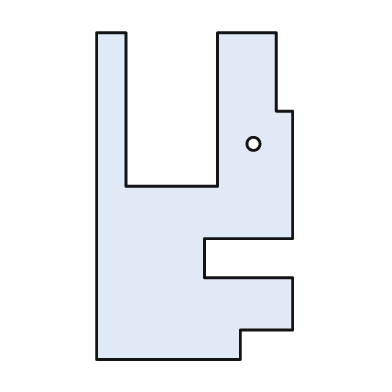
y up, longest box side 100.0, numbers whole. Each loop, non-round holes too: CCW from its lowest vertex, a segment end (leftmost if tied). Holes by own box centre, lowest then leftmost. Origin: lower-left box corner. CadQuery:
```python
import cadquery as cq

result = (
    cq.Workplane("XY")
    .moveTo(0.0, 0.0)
    .lineTo(44.0, 0.0)
    .lineTo(44.0, 9.0)
    .lineTo(60.0, 9.0)
    .lineTo(60.0, 25.0)
    .lineTo(33.0, 25.0)
    .lineTo(33.0, 37.0)
    .lineTo(60.0, 37.0)
    .lineTo(60.0, 76.0)
    .lineTo(55.0, 76.0)
    .lineTo(55.0, 100.0)
    .lineTo(37.0, 100.0)
    .lineTo(37.0, 53.0)
    .lineTo(9.0, 53.0)
    .lineTo(9.0, 100.0)
    .lineTo(0.0, 100.0)
    .close()
    .moveTo(48.0, 66.0)
    .circle(2.0)
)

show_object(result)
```